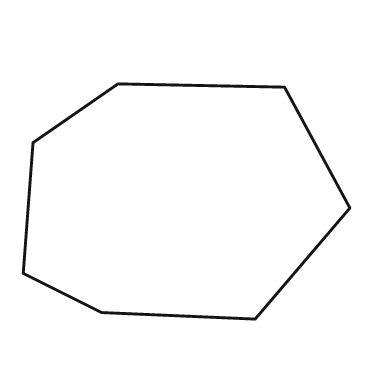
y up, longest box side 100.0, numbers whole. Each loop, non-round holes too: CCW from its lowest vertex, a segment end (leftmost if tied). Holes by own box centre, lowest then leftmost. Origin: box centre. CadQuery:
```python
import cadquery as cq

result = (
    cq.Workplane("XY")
    .moveTo(21.0, -36.0)
    .lineTo(50.0, -2.0)
    .lineTo(30.0, 35.0)
    .lineTo(-21.0, 36.0)
    .lineTo(-47.0, 18.0)
    .lineTo(-50.0, -22.0)
    .lineTo(-26.0, -34.0)
    .close()
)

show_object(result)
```